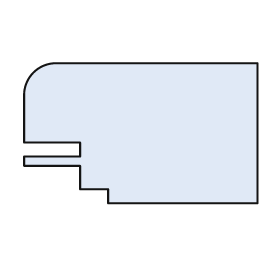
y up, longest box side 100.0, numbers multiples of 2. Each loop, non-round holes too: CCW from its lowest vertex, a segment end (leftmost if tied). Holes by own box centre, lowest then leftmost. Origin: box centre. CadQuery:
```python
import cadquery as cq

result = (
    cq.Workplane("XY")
    .moveTo(-14.0, -30.0)
    .lineTo(50.0, -30.0)
    .lineTo(50.0, 30.0)
    .lineTo(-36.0, 30.0)
    .threePointArc((-46.0, 26.0), (-50.0, 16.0))
    .lineTo(-50.0, -4.0)
    .lineTo(-26.0, -4.0)
    .lineTo(-26.0, -10.0)
    .lineTo(-50.0, -10.0)
    .lineTo(-50.0, -14.0)
    .lineTo(-26.0, -14.0)
    .lineTo(-26.0, -24.0)
    .lineTo(-14.0, -24.0)
    .close()
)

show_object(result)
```